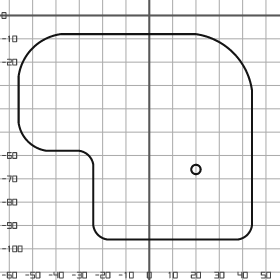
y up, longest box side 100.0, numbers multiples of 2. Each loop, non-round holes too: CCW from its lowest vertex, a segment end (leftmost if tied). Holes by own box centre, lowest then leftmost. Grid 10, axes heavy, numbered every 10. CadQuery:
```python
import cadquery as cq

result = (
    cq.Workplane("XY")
    .moveTo(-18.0, -96.0)
    .lineTo(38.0, -96.0)
    .threePointArc((42.0, -94.0), (44.0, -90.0))
    .lineTo(44.0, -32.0)
    .threePointArc((36.0, -16.0), (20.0, -8.0))
    .lineTo(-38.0, -8.0)
    .threePointArc((-50.0, -14.0), (-56.0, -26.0))
    .lineTo(-56.0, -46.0)
    .threePointArc((-52.0, -54.0), (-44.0, -58.0))
    .lineTo(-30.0, -58.0)
    .threePointArc((-26.0, -60.0), (-24.0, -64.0))
    .lineTo(-24.0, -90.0)
    .threePointArc((-22.0, -94.0), (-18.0, -96.0))
    .close()
    .moveTo(20.0, -66.0)
    .circle(2.0)
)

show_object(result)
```